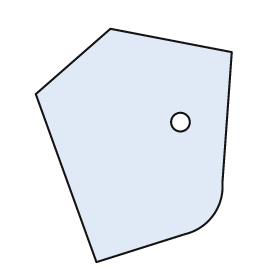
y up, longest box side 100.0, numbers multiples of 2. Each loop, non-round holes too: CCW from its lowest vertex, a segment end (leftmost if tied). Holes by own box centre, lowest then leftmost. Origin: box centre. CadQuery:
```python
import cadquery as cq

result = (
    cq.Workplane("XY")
    .moveTo(-16.0, -50.0)
    .lineTo(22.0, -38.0)
    .threePointArc((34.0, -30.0), (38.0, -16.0))
    .lineTo(42.0, 40.0)
    .lineTo(-10.0, 50.0)
    .lineTo(-42.0, 22.0)
    .close()
    .moveTo(20.0, 10.0)
    .circle(4.0)
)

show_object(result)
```